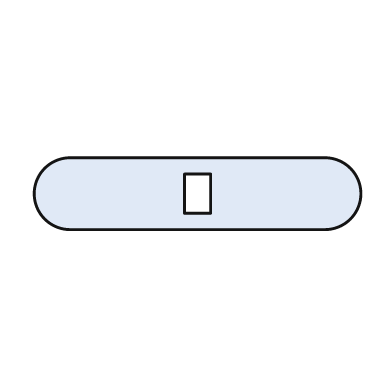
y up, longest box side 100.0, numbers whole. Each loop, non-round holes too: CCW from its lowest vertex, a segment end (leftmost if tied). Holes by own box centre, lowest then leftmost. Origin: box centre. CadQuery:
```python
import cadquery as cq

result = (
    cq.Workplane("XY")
    .moveTo(-39.0, -11.0)
    .lineTo(39.0, -11.0)
    .threePointArc((50.0, 0.0), (39.0, 11.0))
    .lineTo(-39.0, 11.0)
    .threePointArc((-50.0, 0.0), (-39.0, -11.0))
    .close()
    .moveTo(-4.0, -6.0)
    .lineTo(4.0, -6.0)
    .lineTo(4.0, 6.0)
    .lineTo(-4.0, 6.0)
    .close()
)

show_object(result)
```